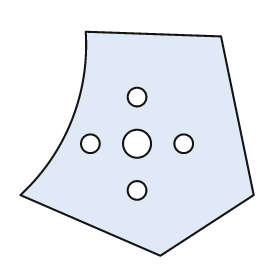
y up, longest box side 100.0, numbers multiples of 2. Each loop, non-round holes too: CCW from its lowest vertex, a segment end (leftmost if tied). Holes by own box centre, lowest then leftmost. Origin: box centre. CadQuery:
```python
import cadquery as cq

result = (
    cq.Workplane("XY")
    .moveTo(10.0, -48.0)
    .lineTo(50.0, -22.0)
    .lineTo(36.0, 46.0)
    .lineTo(-22.0, 48.0)
    .threePointArc((-28.0, 10.0), (-50.0, -22.0))
    .close()
    .moveTo(0.0, -20.0)
    .circle(4.0)
    .moveTo(-20.0, 0.0)
    .circle(4.0)
    .moveTo(0.0, 0.0)
    .circle(6.0)
    .moveTo(20.0, 0.0)
    .circle(4.0)
    .moveTo(0.0, 20.0)
    .circle(4.0)
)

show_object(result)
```